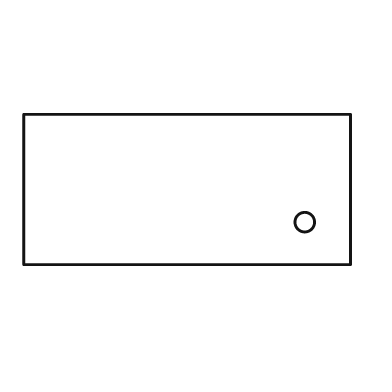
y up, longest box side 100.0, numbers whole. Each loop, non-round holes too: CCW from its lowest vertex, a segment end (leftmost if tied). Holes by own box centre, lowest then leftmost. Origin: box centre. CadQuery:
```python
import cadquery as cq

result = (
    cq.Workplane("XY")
    .moveTo(-50.0, -23.0)
    .lineTo(50.0, -23.0)
    .lineTo(50.0, 23.0)
    .lineTo(-50.0, 23.0)
    .close()
    .moveTo(36.0, -10.0)
    .circle(3.0)
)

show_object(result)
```